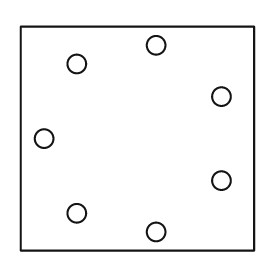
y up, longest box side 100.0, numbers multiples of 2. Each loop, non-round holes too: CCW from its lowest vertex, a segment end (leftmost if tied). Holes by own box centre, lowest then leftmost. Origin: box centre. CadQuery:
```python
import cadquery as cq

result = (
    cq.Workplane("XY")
    .moveTo(-50.0, -48.0)
    .lineTo(50.0, -48.0)
    .lineTo(50.0, 48.0)
    .lineTo(-50.0, 48.0)
    .close()
    .moveTo(8.0, -40.0)
    .circle(4.0)
    .moveTo(-26.0, -32.0)
    .circle(4.0)
    .moveTo(36.0, -18.0)
    .circle(4.0)
    .moveTo(-40.0, 0.0)
    .circle(4.0)
    .moveTo(36.0, 18.0)
    .circle(4.0)
    .moveTo(-26.0, 32.0)
    .circle(4.0)
    .moveTo(8.0, 40.0)
    .circle(4.0)
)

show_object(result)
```